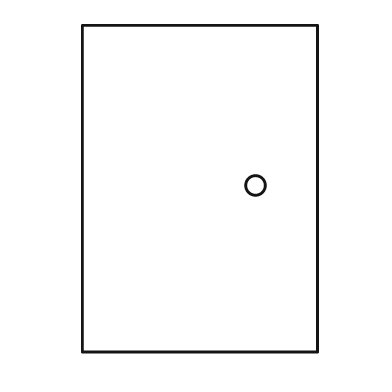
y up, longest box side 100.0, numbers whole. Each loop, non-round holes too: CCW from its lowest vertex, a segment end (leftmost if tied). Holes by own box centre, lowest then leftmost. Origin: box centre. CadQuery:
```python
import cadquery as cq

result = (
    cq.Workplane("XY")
    .moveTo(-36.0, -50.0)
    .lineTo(36.0, -50.0)
    .lineTo(36.0, 50.0)
    .lineTo(-36.0, 50.0)
    .close()
    .moveTo(17.0, 1.0)
    .circle(3.0)
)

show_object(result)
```